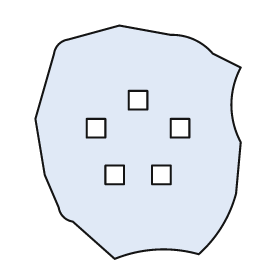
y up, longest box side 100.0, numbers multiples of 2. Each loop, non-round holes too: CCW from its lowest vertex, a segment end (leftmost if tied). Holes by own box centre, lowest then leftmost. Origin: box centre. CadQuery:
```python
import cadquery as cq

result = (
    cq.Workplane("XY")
    .moveTo(-10.0, -50.0)
    .threePointArc((8.0, -46.0), (26.0, -48.0))
    .threePointArc((36.0, -36.0), (42.0, -22.0))
    .lineTo(44.0, 0.0)
    .threePointArc((40.0, 16.0), (44.0, 32.0))
    .lineTo(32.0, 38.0)
    .threePointArc((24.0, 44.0), (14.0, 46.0))
    .lineTo(-8.0, 50.0)
    .lineTo(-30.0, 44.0)
    .threePointArc((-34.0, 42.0), (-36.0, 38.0))
    .lineTo(-44.0, 10.0)
    .lineTo(-40.0, -14.0)
    .lineTo(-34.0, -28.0)
    .threePointArc((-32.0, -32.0), (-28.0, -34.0))
    .close()
    .moveTo(-14.0, -18.0)
    .lineTo(-6.0, -18.0)
    .lineTo(-6.0, -10.0)
    .lineTo(-14.0, -10.0)
    .close()
    .moveTo(6.0, -18.0)
    .lineTo(14.0, -18.0)
    .lineTo(14.0, -10.0)
    .lineTo(6.0, -10.0)
    .close()
    .moveTo(-22.0, 2.0)
    .lineTo(-14.0, 2.0)
    .lineTo(-14.0, 10.0)
    .lineTo(-22.0, 10.0)
    .close()
    .moveTo(14.0, 2.0)
    .lineTo(22.0, 2.0)
    .lineTo(22.0, 10.0)
    .lineTo(14.0, 10.0)
    .close()
    .moveTo(-4.0, 14.0)
    .lineTo(4.0, 14.0)
    .lineTo(4.0, 22.0)
    .lineTo(-4.0, 22.0)
    .close()
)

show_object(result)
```